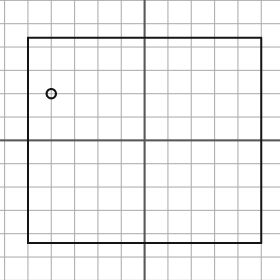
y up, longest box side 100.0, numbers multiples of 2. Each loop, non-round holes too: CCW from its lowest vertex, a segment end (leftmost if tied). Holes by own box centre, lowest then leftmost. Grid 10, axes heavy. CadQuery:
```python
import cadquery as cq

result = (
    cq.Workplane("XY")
    .moveTo(-50.0, -44.0)
    .lineTo(50.0, -44.0)
    .lineTo(50.0, 44.0)
    .lineTo(-50.0, 44.0)
    .close()
    .moveTo(-40.0, 20.0)
    .circle(2.0)
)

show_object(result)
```